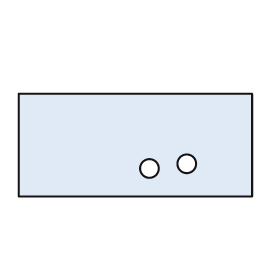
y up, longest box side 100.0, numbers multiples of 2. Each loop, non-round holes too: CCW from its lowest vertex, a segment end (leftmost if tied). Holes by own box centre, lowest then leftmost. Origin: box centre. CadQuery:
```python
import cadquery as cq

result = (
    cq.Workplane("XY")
    .moveTo(-50.0, -22.0)
    .lineTo(50.0, -22.0)
    .lineTo(50.0, 22.0)
    .lineTo(-50.0, 22.0)
    .close()
    .moveTo(6.0, -10.0)
    .circle(4.0)
    .moveTo(22.0, -8.0)
    .circle(4.0)
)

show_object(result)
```